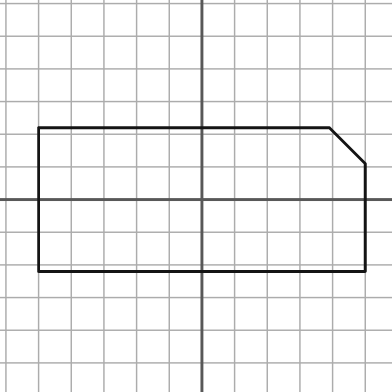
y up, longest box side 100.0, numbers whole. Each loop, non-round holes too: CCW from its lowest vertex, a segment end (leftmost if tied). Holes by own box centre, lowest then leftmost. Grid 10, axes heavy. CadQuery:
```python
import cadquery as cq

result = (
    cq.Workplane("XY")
    .moveTo(-50.0, -22.0)
    .lineTo(50.0, -22.0)
    .lineTo(50.0, 11.0)
    .lineTo(39.0, 22.0)
    .lineTo(-50.0, 22.0)
    .close()
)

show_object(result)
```